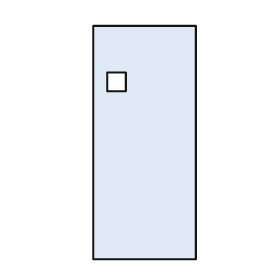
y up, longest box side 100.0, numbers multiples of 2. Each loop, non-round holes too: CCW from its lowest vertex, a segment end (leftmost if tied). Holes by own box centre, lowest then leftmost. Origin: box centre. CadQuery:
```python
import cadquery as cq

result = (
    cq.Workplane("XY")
    .moveTo(-22.0, -50.0)
    .lineTo(22.0, -50.0)
    .lineTo(22.0, 50.0)
    .lineTo(-22.0, 50.0)
    .close()
    .moveTo(-16.0, 22.0)
    .lineTo(-8.0, 22.0)
    .lineTo(-8.0, 30.0)
    .lineTo(-16.0, 30.0)
    .close()
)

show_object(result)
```